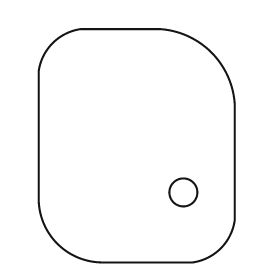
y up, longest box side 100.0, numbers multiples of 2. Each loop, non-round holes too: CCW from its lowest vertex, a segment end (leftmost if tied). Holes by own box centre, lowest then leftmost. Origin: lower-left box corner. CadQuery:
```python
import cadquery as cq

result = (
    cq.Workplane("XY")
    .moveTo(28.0, 0.0)
    .lineTo(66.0, 0.0)
    .threePointArc((78.0, 6.0), (84.0, 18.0))
    .lineTo(84.0, 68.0)
    .threePointArc((74.0, 90.0), (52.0, 100.0))
    .lineTo(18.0, 100.0)
    .threePointArc((6.0, 94.0), (0.0, 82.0))
    .lineTo(0.0, 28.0)
    .threePointArc((8.0, 8.0), (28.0, 0.0))
    .close()
    .moveTo(62.0, 30.0)
    .circle(6.0)
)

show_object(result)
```